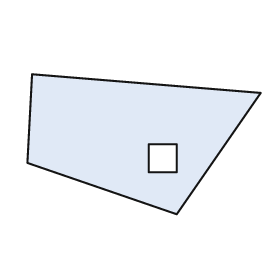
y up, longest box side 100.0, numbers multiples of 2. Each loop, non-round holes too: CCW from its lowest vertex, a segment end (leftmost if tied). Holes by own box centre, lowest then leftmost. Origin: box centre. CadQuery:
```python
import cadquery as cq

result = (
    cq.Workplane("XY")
    .moveTo(14.0, -30.0)
    .lineTo(50.0, 22.0)
    .lineTo(-48.0, 30.0)
    .lineTo(-50.0, -8.0)
    .close()
    .moveTo(2.0, -12.0)
    .lineTo(14.0, -12.0)
    .lineTo(14.0, 0.0)
    .lineTo(2.0, 0.0)
    .close()
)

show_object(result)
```